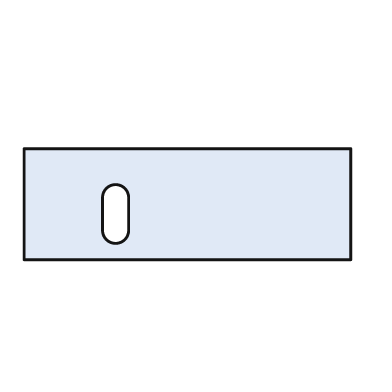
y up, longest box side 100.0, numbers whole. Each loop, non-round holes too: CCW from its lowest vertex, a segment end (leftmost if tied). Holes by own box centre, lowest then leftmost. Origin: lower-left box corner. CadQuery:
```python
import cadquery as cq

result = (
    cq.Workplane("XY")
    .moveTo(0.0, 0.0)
    .lineTo(100.0, 0.0)
    .lineTo(100.0, 34.0)
    .lineTo(0.0, 34.0)
    .close()
    .moveTo(24.0, 9.0)
    .threePointArc((28.0, 5.0), (32.0, 9.0))
    .lineTo(32.0, 19.0)
    .threePointArc((28.0, 23.0), (24.0, 19.0))
    .close()
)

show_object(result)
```